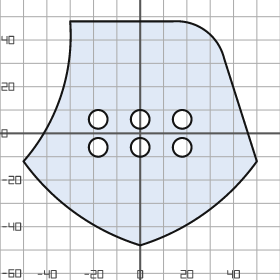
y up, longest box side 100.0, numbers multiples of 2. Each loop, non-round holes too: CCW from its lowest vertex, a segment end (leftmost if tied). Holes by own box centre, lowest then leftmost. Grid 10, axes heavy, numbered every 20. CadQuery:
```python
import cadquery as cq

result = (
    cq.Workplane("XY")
    .moveTo(0.0, -48.0)
    .threePointArc((28.0, -34.0), (50.0, -12.0))
    .lineTo(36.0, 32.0)
    .threePointArc((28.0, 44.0), (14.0, 48.0))
    .lineTo(-30.0, 48.0)
    .threePointArc((-34.0, 16.0), (-50.0, -12.0))
    .threePointArc((-28.0, -34.0), (0.0, -48.0))
    .close()
    .moveTo(-18.0, -6.0)
    .circle(4.0)
    .moveTo(0.0, -6.0)
    .circle(4.0)
    .moveTo(18.0, -6.0)
    .circle(4.0)
    .moveTo(-18.0, 6.0)
    .circle(4.0)
    .moveTo(0.0, 6.0)
    .circle(4.0)
    .moveTo(18.0, 6.0)
    .circle(4.0)
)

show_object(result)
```